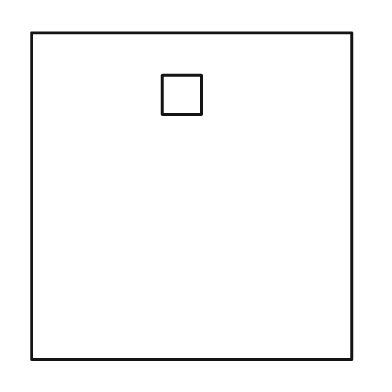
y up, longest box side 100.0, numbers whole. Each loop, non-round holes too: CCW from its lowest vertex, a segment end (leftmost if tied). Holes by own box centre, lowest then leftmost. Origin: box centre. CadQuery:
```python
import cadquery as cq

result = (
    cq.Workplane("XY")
    .moveTo(-49.0, -50.0)
    .lineTo(49.0, -50.0)
    .lineTo(49.0, 50.0)
    .lineTo(-49.0, 50.0)
    .close()
    .moveTo(-9.0, 25.0)
    .lineTo(3.0, 25.0)
    .lineTo(3.0, 37.0)
    .lineTo(-9.0, 37.0)
    .close()
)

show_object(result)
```